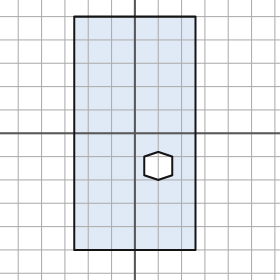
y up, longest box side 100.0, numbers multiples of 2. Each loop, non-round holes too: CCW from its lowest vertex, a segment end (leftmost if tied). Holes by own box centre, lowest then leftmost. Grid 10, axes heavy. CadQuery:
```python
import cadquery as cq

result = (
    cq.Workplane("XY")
    .moveTo(-26.0, -50.0)
    .lineTo(26.0, -50.0)
    .lineTo(26.0, 50.0)
    .lineTo(-26.0, 50.0)
    .close()
    .moveTo(10.0, -20.0)
    .lineTo(16.0, -18.0)
    .lineTo(16.0, -10.0)
    .lineTo(10.0, -8.0)
    .lineTo(4.0, -10.0)
    .lineTo(4.0, -18.0)
    .close()
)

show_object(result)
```